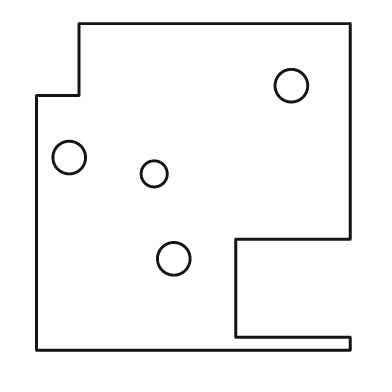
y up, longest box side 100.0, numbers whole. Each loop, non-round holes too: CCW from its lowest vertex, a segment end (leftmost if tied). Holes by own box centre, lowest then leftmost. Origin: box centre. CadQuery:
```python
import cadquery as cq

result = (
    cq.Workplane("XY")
    .moveTo(-48.0, -50.0)
    .lineTo(48.0, -50.0)
    .lineTo(48.0, -46.0)
    .lineTo(13.0, -46.0)
    .lineTo(13.0, -16.0)
    .lineTo(48.0, -16.0)
    .lineTo(48.0, 50.0)
    .lineTo(-35.0, 50.0)
    .lineTo(-35.0, 28.0)
    .lineTo(-48.0, 28.0)
    .close()
    .moveTo(-6.0, -22.0)
    .circle(5.0)
    .moveTo(-12.0, 4.0)
    .circle(4.0)
    .moveTo(-38.0, 9.0)
    .circle(5.0)
    .moveTo(30.0, 31.0)
    .circle(5.0)
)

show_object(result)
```